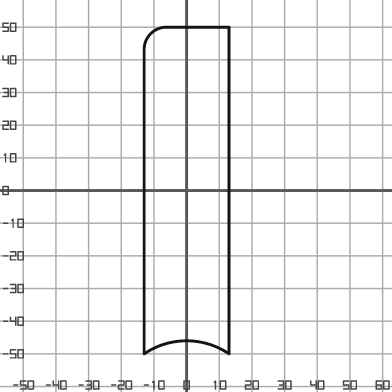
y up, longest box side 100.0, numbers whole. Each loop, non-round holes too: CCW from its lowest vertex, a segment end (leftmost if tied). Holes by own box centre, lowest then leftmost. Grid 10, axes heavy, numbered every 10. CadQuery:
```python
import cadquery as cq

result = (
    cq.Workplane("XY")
    .moveTo(-13.0, -50.0)
    .threePointArc((0.0, -46.0), (13.0, -50.0))
    .lineTo(13.0, 50.0)
    .lineTo(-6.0, 50.0)
    .threePointArc((-11.0, 48.0), (-13.0, 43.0))
    .close()
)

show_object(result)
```